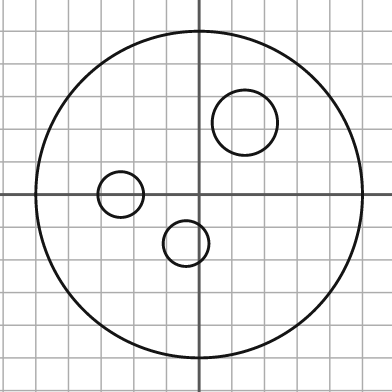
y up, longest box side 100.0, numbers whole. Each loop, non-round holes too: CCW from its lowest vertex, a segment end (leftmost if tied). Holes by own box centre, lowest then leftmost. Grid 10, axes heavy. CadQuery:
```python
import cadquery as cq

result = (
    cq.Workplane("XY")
    .moveTo(0.0, 0.0)
    .circle(50.0)
    .moveTo(-4.0, -15.0)
    .circle(7.0)
    .moveTo(-24.0, 0.0)
    .circle(7.0)
    .moveTo(14.0, 22.0)
    .circle(10.0)
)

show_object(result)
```